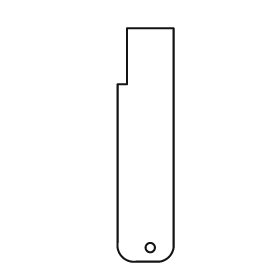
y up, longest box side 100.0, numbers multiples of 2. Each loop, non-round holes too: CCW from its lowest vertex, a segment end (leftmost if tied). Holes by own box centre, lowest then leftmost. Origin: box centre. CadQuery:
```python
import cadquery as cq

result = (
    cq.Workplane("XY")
    .moveTo(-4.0, -50.0)
    .lineTo(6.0, -50.0)
    .threePointArc((10.0, -48.0), (12.0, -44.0))
    .lineTo(12.0, 50.0)
    .lineTo(-8.0, 50.0)
    .lineTo(-8.0, 26.0)
    .lineTo(-12.0, 26.0)
    .lineTo(-12.0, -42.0)
    .threePointArc((-10.0, -48.0), (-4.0, -50.0))
    .close()
    .moveTo(2.0, -44.0)
    .circle(2.0)
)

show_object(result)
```